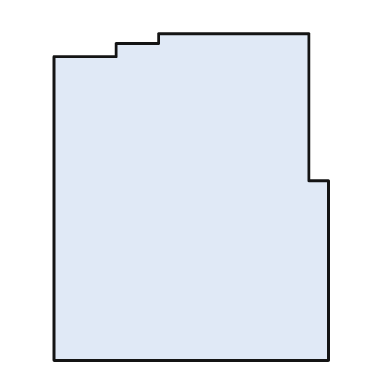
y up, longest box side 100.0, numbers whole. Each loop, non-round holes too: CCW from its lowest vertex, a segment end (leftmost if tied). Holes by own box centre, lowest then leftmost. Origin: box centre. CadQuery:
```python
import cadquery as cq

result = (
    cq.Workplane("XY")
    .moveTo(-42.0, -50.0)
    .lineTo(42.0, -50.0)
    .lineTo(42.0, 5.0)
    .lineTo(36.0, 5.0)
    .lineTo(36.0, 50.0)
    .lineTo(-10.0, 50.0)
    .lineTo(-10.0, 47.0)
    .lineTo(-23.0, 47.0)
    .lineTo(-23.0, 43.0)
    .lineTo(-42.0, 43.0)
    .close()
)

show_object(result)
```